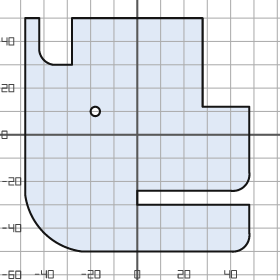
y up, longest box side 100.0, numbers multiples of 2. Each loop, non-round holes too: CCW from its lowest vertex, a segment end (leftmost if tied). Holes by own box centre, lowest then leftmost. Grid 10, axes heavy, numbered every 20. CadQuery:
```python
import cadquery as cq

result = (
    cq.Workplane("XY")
    .moveTo(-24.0, -50.0)
    .lineTo(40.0, -50.0)
    .threePointArc((46.0, -48.0), (48.0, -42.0))
    .lineTo(48.0, -30.0)
    .lineTo(0.0, -30.0)
    .lineTo(0.0, -24.0)
    .lineTo(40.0, -24.0)
    .threePointArc((46.0, -22.0), (48.0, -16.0))
    .lineTo(48.0, 12.0)
    .lineTo(28.0, 12.0)
    .lineTo(28.0, 50.0)
    .lineTo(-28.0, 50.0)
    .lineTo(-28.0, 30.0)
    .lineTo(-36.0, 30.0)
    .threePointArc((-40.0, 32.0), (-42.0, 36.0))
    .lineTo(-42.0, 50.0)
    .lineTo(-48.0, 50.0)
    .lineTo(-48.0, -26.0)
    .threePointArc((-40.0, -42.0), (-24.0, -50.0))
    .close()
    .moveTo(-18.0, 10.0)
    .circle(2.0)
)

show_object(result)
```